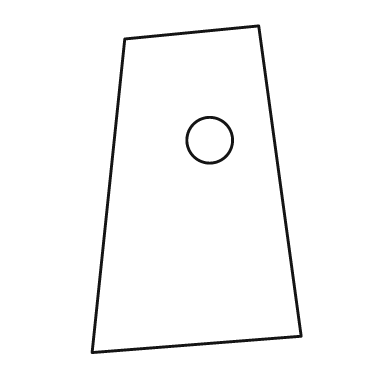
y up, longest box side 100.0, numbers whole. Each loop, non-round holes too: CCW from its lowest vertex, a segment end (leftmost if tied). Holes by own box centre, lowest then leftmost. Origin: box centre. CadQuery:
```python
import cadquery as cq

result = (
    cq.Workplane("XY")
    .moveTo(-32.0, -50.0)
    .lineTo(32.0, -45.0)
    .lineTo(19.0, 50.0)
    .lineTo(-22.0, 46.0)
    .close()
    .moveTo(4.0, 15.0)
    .circle(7.0)
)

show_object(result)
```